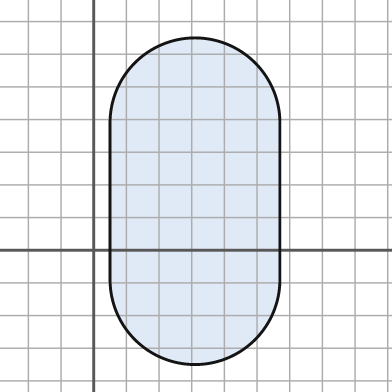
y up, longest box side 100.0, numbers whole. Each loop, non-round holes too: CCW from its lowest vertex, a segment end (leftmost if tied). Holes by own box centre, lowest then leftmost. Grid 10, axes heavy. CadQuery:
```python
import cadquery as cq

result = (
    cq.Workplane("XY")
    .moveTo(5.0, -9.0)
    .threePointArc((31.0, -35.0), (57.0, -9.0))
    .lineTo(57.0, 39.0)
    .threePointArc((31.0, 65.0), (5.0, 39.0))
    .close()
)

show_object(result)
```